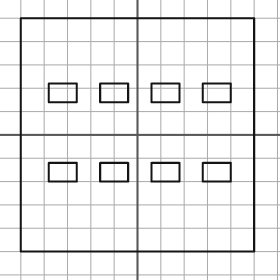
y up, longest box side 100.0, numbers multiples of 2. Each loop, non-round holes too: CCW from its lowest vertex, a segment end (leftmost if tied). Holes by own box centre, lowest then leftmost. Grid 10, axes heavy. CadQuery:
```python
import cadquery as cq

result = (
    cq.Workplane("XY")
    .moveTo(-50.0, -50.0)
    .lineTo(50.0, -50.0)
    .lineTo(50.0, 50.0)
    .lineTo(-50.0, 50.0)
    .close()
    .moveTo(-38.0, -20.0)
    .lineTo(-26.0, -20.0)
    .lineTo(-26.0, -12.0)
    .lineTo(-38.0, -12.0)
    .close()
    .moveTo(-16.0, -20.0)
    .lineTo(-4.0, -20.0)
    .lineTo(-4.0, -12.0)
    .lineTo(-16.0, -12.0)
    .close()
    .moveTo(6.0, -20.0)
    .lineTo(18.0, -20.0)
    .lineTo(18.0, -12.0)
    .lineTo(6.0, -12.0)
    .close()
    .moveTo(28.0, -20.0)
    .lineTo(40.0, -20.0)
    .lineTo(40.0, -12.0)
    .lineTo(28.0, -12.0)
    .close()
    .moveTo(-38.0, 14.0)
    .lineTo(-26.0, 14.0)
    .lineTo(-26.0, 22.0)
    .lineTo(-38.0, 22.0)
    .close()
    .moveTo(-16.0, 14.0)
    .lineTo(-4.0, 14.0)
    .lineTo(-4.0, 22.0)
    .lineTo(-16.0, 22.0)
    .close()
    .moveTo(6.0, 14.0)
    .lineTo(18.0, 14.0)
    .lineTo(18.0, 22.0)
    .lineTo(6.0, 22.0)
    .close()
    .moveTo(28.0, 14.0)
    .lineTo(40.0, 14.0)
    .lineTo(40.0, 22.0)
    .lineTo(28.0, 22.0)
    .close()
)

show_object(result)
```